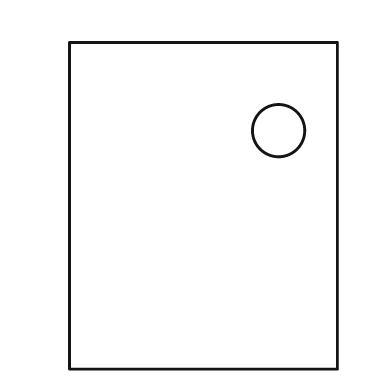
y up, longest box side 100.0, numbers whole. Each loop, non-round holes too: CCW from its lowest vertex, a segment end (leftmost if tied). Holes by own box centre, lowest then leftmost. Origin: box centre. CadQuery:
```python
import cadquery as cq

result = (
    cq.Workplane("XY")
    .moveTo(-41.0, -50.0)
    .lineTo(41.0, -50.0)
    .lineTo(41.0, 50.0)
    .lineTo(-41.0, 50.0)
    .close()
    .moveTo(23.0, 23.0)
    .circle(8.0)
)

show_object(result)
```